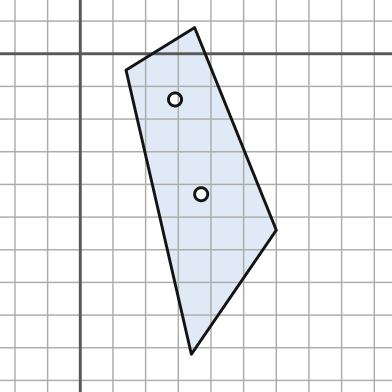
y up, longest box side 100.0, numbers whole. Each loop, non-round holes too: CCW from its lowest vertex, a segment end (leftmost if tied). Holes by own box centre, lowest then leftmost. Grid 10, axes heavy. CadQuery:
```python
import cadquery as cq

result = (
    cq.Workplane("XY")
    .moveTo(34.0, -92.0)
    .lineTo(60.0, -54.0)
    .lineTo(35.0, 8.0)
    .lineTo(14.0, -5.0)
    .close()
    .moveTo(37.0, -43.0)
    .circle(2.0)
    .moveTo(29.0, -14.0)
    .circle(2.0)
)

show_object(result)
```